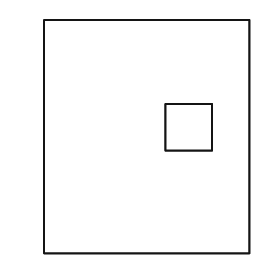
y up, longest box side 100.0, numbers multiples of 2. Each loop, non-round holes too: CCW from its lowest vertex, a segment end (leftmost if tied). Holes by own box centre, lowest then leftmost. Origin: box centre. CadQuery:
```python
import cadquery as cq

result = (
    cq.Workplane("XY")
    .moveTo(-44.0, -50.0)
    .lineTo(44.0, -50.0)
    .lineTo(44.0, 50.0)
    .lineTo(-44.0, 50.0)
    .close()
    .moveTo(8.0, -6.0)
    .lineTo(28.0, -6.0)
    .lineTo(28.0, 14.0)
    .lineTo(8.0, 14.0)
    .close()
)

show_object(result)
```